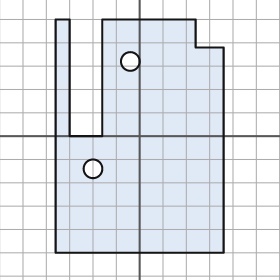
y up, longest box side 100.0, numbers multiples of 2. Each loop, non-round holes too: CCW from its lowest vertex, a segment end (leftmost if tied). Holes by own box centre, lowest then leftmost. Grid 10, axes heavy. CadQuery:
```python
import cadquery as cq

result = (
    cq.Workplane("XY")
    .moveTo(-36.0, -50.0)
    .lineTo(36.0, -50.0)
    .lineTo(36.0, 38.0)
    .lineTo(24.0, 38.0)
    .lineTo(24.0, 50.0)
    .lineTo(-16.0, 50.0)
    .lineTo(-16.0, 0.0)
    .lineTo(-30.0, 0.0)
    .lineTo(-30.0, 50.0)
    .lineTo(-36.0, 50.0)
    .close()
    .moveTo(-20.0, -14.0)
    .circle(4.0)
    .moveTo(-4.0, 32.0)
    .circle(4.0)
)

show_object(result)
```